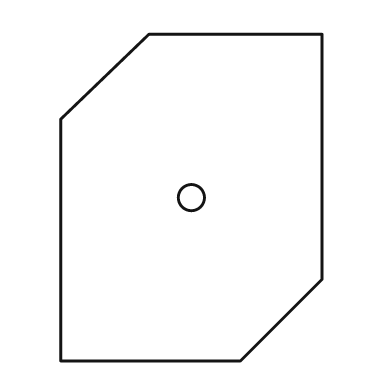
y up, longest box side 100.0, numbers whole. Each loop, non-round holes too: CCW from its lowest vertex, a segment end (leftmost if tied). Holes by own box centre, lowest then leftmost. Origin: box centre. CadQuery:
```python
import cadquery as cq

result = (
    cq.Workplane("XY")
    .moveTo(-40.0, -50.0)
    .lineTo(15.0, -50.0)
    .lineTo(40.0, -25.0)
    .lineTo(40.0, 50.0)
    .lineTo(-13.0, 50.0)
    .lineTo(-40.0, 24.0)
    .close()
    .moveTo(0.0, 0.0)
    .circle(4.0)
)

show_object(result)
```